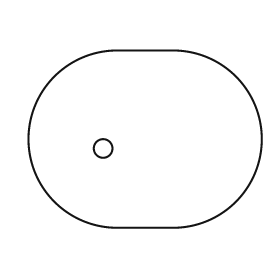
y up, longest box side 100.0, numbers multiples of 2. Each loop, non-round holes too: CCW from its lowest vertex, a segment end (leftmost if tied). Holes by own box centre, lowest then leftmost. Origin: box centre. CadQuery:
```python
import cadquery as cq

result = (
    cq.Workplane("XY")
    .moveTo(-12.0, -38.0)
    .lineTo(12.0, -38.0)
    .threePointArc((50.0, 0.0), (12.0, 38.0))
    .lineTo(-12.0, 38.0)
    .threePointArc((-50.0, 0.0), (-12.0, -38.0))
    .close()
    .moveTo(-18.0, -4.0)
    .circle(4.0)
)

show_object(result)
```